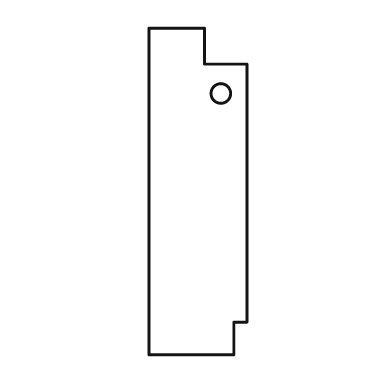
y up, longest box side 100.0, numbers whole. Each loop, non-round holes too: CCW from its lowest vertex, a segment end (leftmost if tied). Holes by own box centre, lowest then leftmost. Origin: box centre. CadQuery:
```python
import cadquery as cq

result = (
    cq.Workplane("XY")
    .moveTo(-15.0, -50.0)
    .lineTo(11.0, -50.0)
    .lineTo(11.0, -40.0)
    .lineTo(15.0, -40.0)
    .lineTo(15.0, 39.0)
    .lineTo(2.0, 39.0)
    .lineTo(2.0, 50.0)
    .lineTo(-15.0, 50.0)
    .close()
    .moveTo(7.0, 30.0)
    .circle(3.0)
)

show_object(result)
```